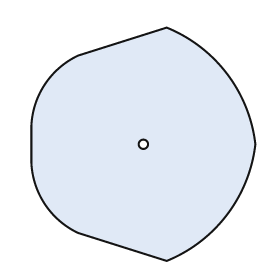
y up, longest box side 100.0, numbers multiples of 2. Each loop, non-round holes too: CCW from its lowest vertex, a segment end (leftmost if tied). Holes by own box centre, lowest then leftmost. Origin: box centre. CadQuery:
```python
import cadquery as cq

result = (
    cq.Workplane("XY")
    .moveTo(10.0, -50.0)
    .threePointArc((36.0, -30.0), (48.0, 0.0))
    .threePointArc((36.0, 30.0), (10.0, 50.0))
    .lineTo(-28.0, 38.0)
    .threePointArc((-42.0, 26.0), (-48.0, 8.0))
    .lineTo(-48.0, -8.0)
    .threePointArc((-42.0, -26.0), (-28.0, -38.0))
    .close()
    .moveTo(0.0, 0.0)
    .circle(2.0)
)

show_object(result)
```